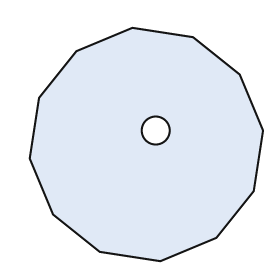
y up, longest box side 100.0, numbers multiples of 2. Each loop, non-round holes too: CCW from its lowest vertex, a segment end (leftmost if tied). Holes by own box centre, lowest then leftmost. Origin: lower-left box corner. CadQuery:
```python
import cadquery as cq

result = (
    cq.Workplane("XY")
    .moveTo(56.0, 0.0)
    .lineTo(80.0, 10.0)
    .lineTo(96.0, 30.0)
    .lineTo(100.0, 56.0)
    .lineTo(90.0, 80.0)
    .lineTo(70.0, 96.0)
    .lineTo(44.0, 100.0)
    .lineTo(20.0, 90.0)
    .lineTo(4.0, 70.0)
    .lineTo(0.0, 44.0)
    .lineTo(10.0, 20.0)
    .lineTo(30.0, 4.0)
    .close()
    .moveTo(54.0, 56.0)
    .circle(6.0)
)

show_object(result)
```